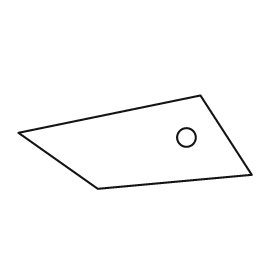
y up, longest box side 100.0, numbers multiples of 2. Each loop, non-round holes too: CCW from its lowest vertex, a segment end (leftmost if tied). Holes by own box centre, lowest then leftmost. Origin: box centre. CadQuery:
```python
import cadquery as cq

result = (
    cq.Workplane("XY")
    .moveTo(-16.0, -20.0)
    .lineTo(50.0, -14.0)
    .lineTo(28.0, 20.0)
    .lineTo(-50.0, 4.0)
    .close()
    .moveTo(22.0, 2.0)
    .circle(4.0)
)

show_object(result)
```